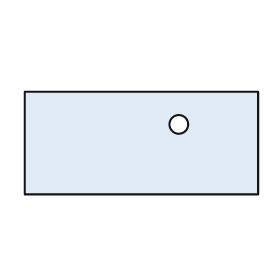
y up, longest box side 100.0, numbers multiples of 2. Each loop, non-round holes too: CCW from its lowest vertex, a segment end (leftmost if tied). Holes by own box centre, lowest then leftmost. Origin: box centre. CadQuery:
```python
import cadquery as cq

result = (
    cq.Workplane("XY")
    .moveTo(-50.0, -22.0)
    .lineTo(50.0, -22.0)
    .lineTo(50.0, 22.0)
    .lineTo(-50.0, 22.0)
    .close()
    .moveTo(16.0, 8.0)
    .circle(4.0)
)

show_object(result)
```